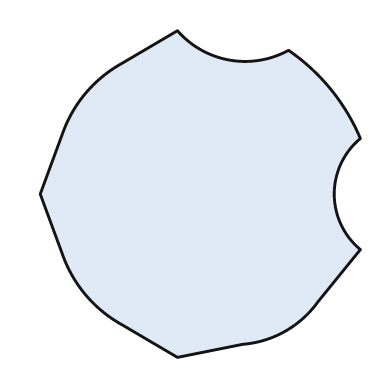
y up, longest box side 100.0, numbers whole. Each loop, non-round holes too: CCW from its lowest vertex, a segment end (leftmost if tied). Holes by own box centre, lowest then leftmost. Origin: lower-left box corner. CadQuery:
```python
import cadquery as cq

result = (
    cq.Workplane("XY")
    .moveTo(42.0, 0.0)
    .lineTo(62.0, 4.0)
    .threePointArc((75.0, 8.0), (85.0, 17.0))
    .lineTo(98.0, 33.0)
    .threePointArc((90.0, 50.0), (98.0, 67.0))
    .threePointArc((89.0, 82.0), (76.0, 94.0))
    .threePointArc((58.0, 91.0), (42.0, 100.0))
    .lineTo(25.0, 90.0)
    .threePointArc((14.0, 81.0), (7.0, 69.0))
    .lineTo(0.0, 50.0)
    .lineTo(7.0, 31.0)
    .threePointArc((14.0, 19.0), (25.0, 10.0))
    .close()
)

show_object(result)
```